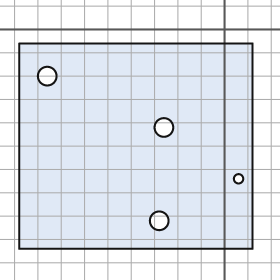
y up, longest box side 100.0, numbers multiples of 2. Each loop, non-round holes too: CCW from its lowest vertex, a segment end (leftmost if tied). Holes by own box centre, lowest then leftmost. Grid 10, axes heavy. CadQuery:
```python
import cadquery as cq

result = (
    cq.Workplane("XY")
    .moveTo(-88.0, -94.0)
    .lineTo(12.0, -94.0)
    .lineTo(12.0, -6.0)
    .lineTo(-88.0, -6.0)
    .close()
    .moveTo(-28.0, -82.0)
    .circle(4.0)
    .moveTo(6.0, -64.0)
    .circle(2.0)
    .moveTo(-26.0, -42.0)
    .circle(4.0)
    .moveTo(-76.0, -20.0)
    .circle(4.0)
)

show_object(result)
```